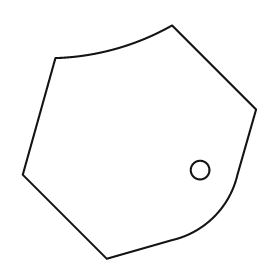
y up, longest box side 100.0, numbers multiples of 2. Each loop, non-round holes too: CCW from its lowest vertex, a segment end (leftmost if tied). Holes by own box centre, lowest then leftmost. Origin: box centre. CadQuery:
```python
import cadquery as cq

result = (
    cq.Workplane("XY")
    .moveTo(-14.0, -50.0)
    .lineTo(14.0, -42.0)
    .threePointArc((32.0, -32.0), (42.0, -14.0))
    .lineTo(50.0, 14.0)
    .lineTo(14.0, 50.0)
    .threePointArc((-10.0, 40.0), (-36.0, 36.0))
    .lineTo(-50.0, -14.0)
    .close()
    .moveTo(26.0, -12.0)
    .circle(4.0)
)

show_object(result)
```